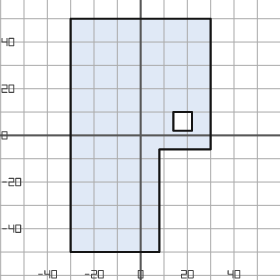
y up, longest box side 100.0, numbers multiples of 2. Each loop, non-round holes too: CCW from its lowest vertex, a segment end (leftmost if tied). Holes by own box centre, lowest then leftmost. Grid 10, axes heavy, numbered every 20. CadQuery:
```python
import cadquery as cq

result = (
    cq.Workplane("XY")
    .moveTo(-30.0, -50.0)
    .lineTo(8.0, -50.0)
    .lineTo(8.0, -6.0)
    .lineTo(30.0, -6.0)
    .lineTo(30.0, 50.0)
    .lineTo(-30.0, 50.0)
    .close()
    .moveTo(14.0, 2.0)
    .lineTo(22.0, 2.0)
    .lineTo(22.0, 10.0)
    .lineTo(14.0, 10.0)
    .close()
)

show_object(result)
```